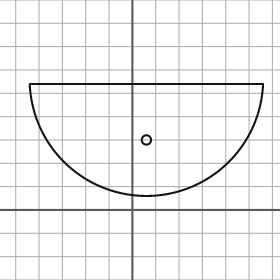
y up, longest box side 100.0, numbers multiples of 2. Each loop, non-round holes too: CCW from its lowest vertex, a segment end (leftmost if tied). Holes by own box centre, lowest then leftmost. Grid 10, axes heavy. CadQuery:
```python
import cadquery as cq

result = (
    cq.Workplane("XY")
    .moveTo(-44.0, 54.0)
    .threePointArc((6.0, 6.0), (56.0, 54.0))
    .close()
    .moveTo(6.0, 30.0)
    .circle(2.0)
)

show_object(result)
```